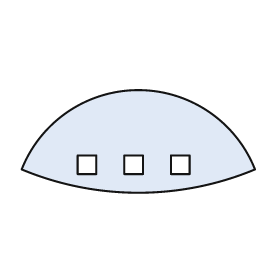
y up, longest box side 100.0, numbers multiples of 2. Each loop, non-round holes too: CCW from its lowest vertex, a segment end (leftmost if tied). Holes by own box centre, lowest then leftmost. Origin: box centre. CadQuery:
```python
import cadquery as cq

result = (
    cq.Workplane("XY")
    .moveTo(-50.0, -12.0)
    .threePointArc((0.0, -22.0), (50.0, -12.0))
    .threePointArc((0.0, 22.0), (-50.0, -12.0))
    .close()
    .moveTo(-26.0, -14.0)
    .lineTo(-18.0, -14.0)
    .lineTo(-18.0, -6.0)
    .lineTo(-26.0, -6.0)
    .close()
    .moveTo(-6.0, -14.0)
    .lineTo(2.0, -14.0)
    .lineTo(2.0, -6.0)
    .lineTo(-6.0, -6.0)
    .close()
    .moveTo(14.0, -14.0)
    .lineTo(22.0, -14.0)
    .lineTo(22.0, -6.0)
    .lineTo(14.0, -6.0)
    .close()
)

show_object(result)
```